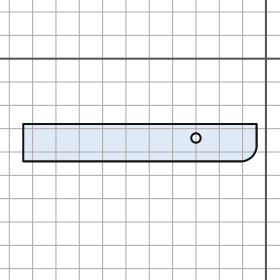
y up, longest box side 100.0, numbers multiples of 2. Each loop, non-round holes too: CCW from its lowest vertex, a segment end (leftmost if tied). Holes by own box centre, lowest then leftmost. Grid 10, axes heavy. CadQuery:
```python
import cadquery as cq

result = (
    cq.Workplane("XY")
    .moveTo(-104.0, -44.0)
    .lineTo(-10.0, -44.0)
    .threePointArc((-6.0, -42.0), (-4.0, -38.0))
    .lineTo(-4.0, -28.0)
    .lineTo(-104.0, -28.0)
    .close()
    .moveTo(-30.0, -34.0)
    .circle(2.0)
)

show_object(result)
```